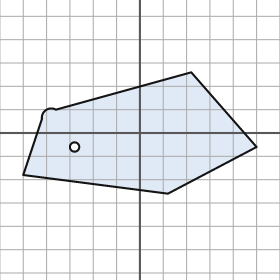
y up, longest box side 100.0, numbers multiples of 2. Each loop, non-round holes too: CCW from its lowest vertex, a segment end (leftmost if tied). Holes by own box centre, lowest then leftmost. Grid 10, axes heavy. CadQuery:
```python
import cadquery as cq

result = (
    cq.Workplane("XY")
    .moveTo(12.0, -26.0)
    .lineTo(50.0, -6.0)
    .lineTo(22.0, 26.0)
    .lineTo(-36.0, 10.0)
    .threePointArc((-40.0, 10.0), (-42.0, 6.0))
    .lineTo(-50.0, -18.0)
    .close()
    .moveTo(-28.0, -6.0)
    .circle(2.0)
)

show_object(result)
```